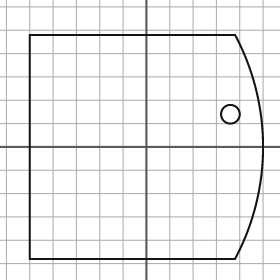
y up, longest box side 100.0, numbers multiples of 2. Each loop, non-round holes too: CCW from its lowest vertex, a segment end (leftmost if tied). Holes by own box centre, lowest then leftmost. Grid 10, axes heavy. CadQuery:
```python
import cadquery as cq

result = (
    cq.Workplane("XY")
    .moveTo(-50.0, -48.0)
    .lineTo(38.0, -48.0)
    .threePointArc((50.0, 0.0), (38.0, 48.0))
    .lineTo(-50.0, 48.0)
    .close()
    .moveTo(36.0, 14.0)
    .circle(4.0)
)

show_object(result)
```